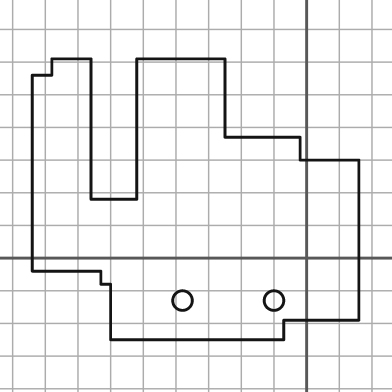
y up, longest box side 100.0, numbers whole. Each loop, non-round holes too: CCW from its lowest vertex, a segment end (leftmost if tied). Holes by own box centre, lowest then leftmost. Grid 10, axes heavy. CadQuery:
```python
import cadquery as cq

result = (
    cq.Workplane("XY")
    .moveTo(-60.0, -25.0)
    .lineTo(-7.0, -25.0)
    .lineTo(-7.0, -19.0)
    .lineTo(16.0, -19.0)
    .lineTo(16.0, 30.0)
    .lineTo(-2.0, 30.0)
    .lineTo(-2.0, 37.0)
    .lineTo(-25.0, 37.0)
    .lineTo(-25.0, 61.0)
    .lineTo(-52.0, 61.0)
    .lineTo(-52.0, 18.0)
    .lineTo(-66.0, 18.0)
    .lineTo(-66.0, 61.0)
    .lineTo(-78.0, 61.0)
    .lineTo(-78.0, 56.0)
    .lineTo(-84.0, 56.0)
    .lineTo(-84.0, -4.0)
    .lineTo(-63.0, -4.0)
    .lineTo(-63.0, -8.0)
    .lineTo(-60.0, -8.0)
    .close()
    .moveTo(-38.0, -13.0)
    .circle(3.0)
    .moveTo(-10.0, -13.0)
    .circle(3.0)
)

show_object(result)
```